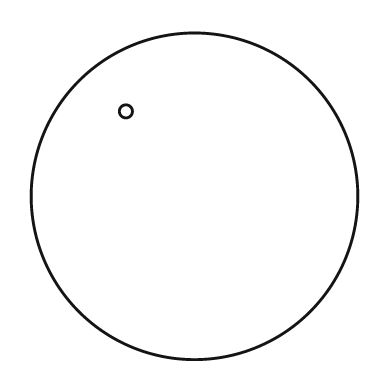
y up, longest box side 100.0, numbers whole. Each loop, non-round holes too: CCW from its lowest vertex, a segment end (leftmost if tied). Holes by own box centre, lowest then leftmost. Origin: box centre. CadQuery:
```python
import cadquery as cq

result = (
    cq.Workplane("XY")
    .moveTo(0.0, 0.0)
    .circle(50.0)
    .moveTo(-21.0, 26.0)
    .circle(2.0)
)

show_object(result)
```